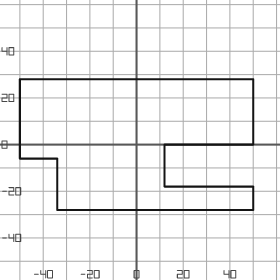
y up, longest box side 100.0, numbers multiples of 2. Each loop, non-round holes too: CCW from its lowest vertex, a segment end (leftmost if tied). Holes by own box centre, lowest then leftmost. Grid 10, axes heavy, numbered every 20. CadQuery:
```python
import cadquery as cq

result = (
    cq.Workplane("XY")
    .moveTo(-34.0, -28.0)
    .lineTo(50.0, -28.0)
    .lineTo(50.0, -18.0)
    .lineTo(12.0, -18.0)
    .lineTo(12.0, 0.0)
    .lineTo(50.0, 0.0)
    .lineTo(50.0, 28.0)
    .lineTo(-50.0, 28.0)
    .lineTo(-50.0, -6.0)
    .lineTo(-34.0, -6.0)
    .close()
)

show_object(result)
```